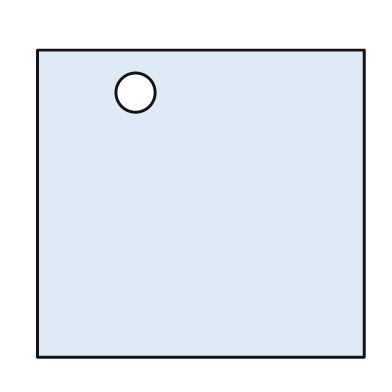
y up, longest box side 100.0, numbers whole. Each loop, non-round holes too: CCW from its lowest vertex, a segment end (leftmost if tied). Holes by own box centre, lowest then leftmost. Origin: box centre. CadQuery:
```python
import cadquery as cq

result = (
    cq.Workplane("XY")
    .moveTo(-50.0, -47.0)
    .lineTo(50.0, -47.0)
    .lineTo(50.0, 47.0)
    .lineTo(-50.0, 47.0)
    .close()
    .moveTo(-20.0, 34.0)
    .circle(6.0)
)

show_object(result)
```